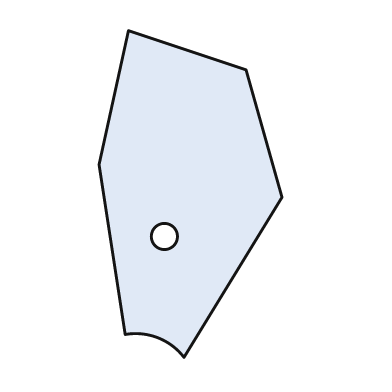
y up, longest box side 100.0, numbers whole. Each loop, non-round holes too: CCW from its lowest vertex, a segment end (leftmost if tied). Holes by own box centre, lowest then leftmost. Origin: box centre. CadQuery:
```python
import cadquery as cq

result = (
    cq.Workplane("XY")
    .moveTo(-2.0, -50.0)
    .lineTo(28.0, -1.0)
    .lineTo(17.0, 38.0)
    .lineTo(-19.0, 50.0)
    .lineTo(-28.0, 9.0)
    .lineTo(-20.0, -43.0)
    .threePointArc((-10.0, -44.0), (-2.0, -50.0))
    .close()
    .moveTo(-8.0, -13.0)
    .circle(4.0)
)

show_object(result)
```